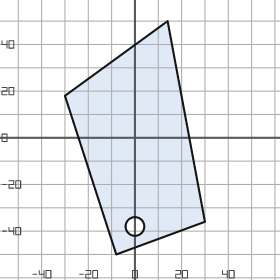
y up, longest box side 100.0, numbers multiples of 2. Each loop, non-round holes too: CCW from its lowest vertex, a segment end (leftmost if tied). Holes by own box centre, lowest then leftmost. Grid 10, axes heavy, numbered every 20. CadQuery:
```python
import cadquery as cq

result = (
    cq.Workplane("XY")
    .moveTo(-8.0, -50.0)
    .lineTo(30.0, -36.0)
    .lineTo(14.0, 50.0)
    .lineTo(-30.0, 18.0)
    .close()
    .moveTo(0.0, -38.0)
    .circle(4.0)
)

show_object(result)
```